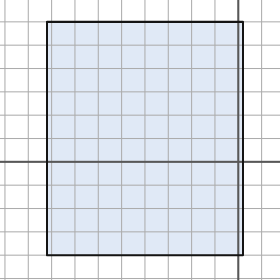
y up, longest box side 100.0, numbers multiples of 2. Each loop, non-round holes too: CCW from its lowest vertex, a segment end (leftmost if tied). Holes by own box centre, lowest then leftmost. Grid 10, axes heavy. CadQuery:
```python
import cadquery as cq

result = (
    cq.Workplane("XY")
    .moveTo(-82.0, -40.0)
    .lineTo(2.0, -40.0)
    .lineTo(2.0, 60.0)
    .lineTo(-82.0, 60.0)
    .close()
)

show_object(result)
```